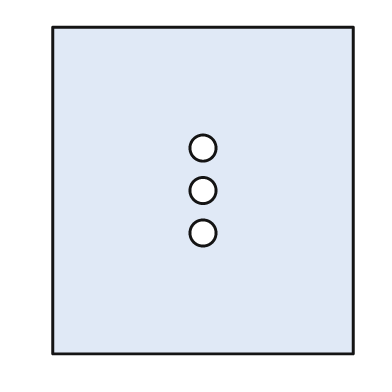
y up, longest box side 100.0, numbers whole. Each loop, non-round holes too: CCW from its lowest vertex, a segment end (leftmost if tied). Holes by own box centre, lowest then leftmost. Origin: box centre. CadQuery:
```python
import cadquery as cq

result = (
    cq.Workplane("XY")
    .moveTo(-46.0, -50.0)
    .lineTo(46.0, -50.0)
    .lineTo(46.0, 50.0)
    .lineTo(-46.0, 50.0)
    .close()
    .moveTo(0.0, -13.0)
    .circle(4.0)
    .moveTo(0.0, 0.0)
    .circle(4.0)
    .moveTo(0.0, 13.0)
    .circle(4.0)
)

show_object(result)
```